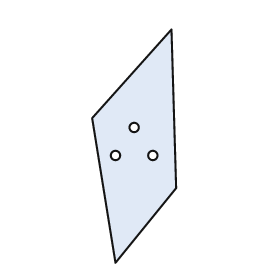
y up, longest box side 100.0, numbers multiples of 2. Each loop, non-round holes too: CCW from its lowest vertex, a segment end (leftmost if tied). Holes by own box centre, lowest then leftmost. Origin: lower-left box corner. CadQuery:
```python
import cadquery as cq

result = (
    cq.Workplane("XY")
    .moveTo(10.0, 0.0)
    .lineTo(36.0, 32.0)
    .lineTo(34.0, 100.0)
    .lineTo(0.0, 62.0)
    .close()
    .moveTo(10.0, 46.0)
    .circle(2.0)
    .moveTo(26.0, 46.0)
    .circle(2.0)
    .moveTo(18.0, 58.0)
    .circle(2.0)
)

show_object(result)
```